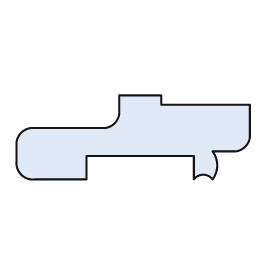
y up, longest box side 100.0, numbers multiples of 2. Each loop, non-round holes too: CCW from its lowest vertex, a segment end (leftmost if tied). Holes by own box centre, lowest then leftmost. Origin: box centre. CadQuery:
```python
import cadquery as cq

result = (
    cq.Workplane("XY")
    .moveTo(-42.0, -18.0)
    .lineTo(-20.0, -18.0)
    .lineTo(-20.0, -8.0)
    .lineTo(26.0, -8.0)
    .lineTo(26.0, -18.0)
    .threePointArc((30.0, -16.0), (34.0, -18.0))
    .threePointArc((36.0, -12.0), (34.0, -6.0))
    .lineTo(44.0, -6.0)
    .threePointArc((48.0, -4.0), (50.0, 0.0))
    .lineTo(50.0, 14.0)
    .lineTo(12.0, 14.0)
    .lineTo(12.0, 18.0)
    .lineTo(-6.0, 18.0)
    .lineTo(-6.0, 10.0)
    .threePointArc((-8.0, 6.0), (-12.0, 4.0))
    .lineTo(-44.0, 4.0)
    .threePointArc((-48.0, 2.0), (-50.0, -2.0))
    .lineTo(-50.0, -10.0)
    .threePointArc((-48.0, -16.0), (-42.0, -18.0))
    .close()
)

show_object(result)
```